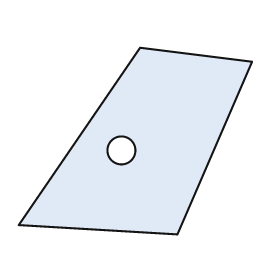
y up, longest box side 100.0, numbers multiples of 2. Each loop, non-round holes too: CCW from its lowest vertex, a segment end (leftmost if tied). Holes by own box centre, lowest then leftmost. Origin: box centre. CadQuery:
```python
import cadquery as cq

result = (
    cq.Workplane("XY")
    .moveTo(18.0, -40.0)
    .lineTo(50.0, 34.0)
    .lineTo(2.0, 40.0)
    .lineTo(-50.0, -36.0)
    .close()
    .moveTo(-6.0, -4.0)
    .circle(6.0)
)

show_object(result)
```